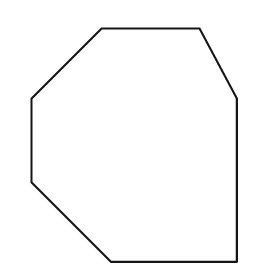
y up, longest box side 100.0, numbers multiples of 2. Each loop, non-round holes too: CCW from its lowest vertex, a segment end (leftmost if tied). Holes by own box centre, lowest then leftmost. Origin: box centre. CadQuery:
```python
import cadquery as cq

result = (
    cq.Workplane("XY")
    .moveTo(-10.0, -50.0)
    .lineTo(44.0, -50.0)
    .lineTo(44.0, 20.0)
    .lineTo(28.0, 50.0)
    .lineTo(-14.0, 50.0)
    .lineTo(-44.0, 20.0)
    .lineTo(-44.0, -16.0)
    .close()
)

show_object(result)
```